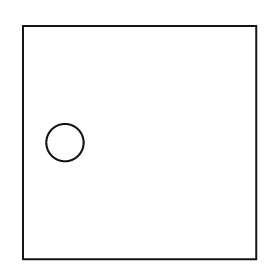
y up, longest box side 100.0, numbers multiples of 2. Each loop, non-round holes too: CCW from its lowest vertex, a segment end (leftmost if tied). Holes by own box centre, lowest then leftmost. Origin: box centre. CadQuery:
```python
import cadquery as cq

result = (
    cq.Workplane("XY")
    .moveTo(-50.0, -50.0)
    .lineTo(50.0, -50.0)
    .lineTo(50.0, 50.0)
    .lineTo(-50.0, 50.0)
    .close()
    .moveTo(-32.0, 0.0)
    .circle(8.0)
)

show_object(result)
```